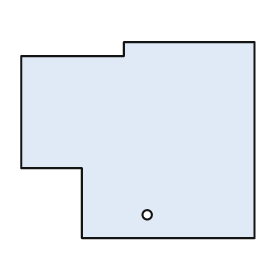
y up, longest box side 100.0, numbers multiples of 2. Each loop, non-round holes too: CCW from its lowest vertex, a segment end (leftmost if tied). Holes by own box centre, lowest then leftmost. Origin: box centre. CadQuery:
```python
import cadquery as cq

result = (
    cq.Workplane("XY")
    .moveTo(-24.0, -42.0)
    .lineTo(50.0, -42.0)
    .lineTo(50.0, 42.0)
    .lineTo(-6.0, 42.0)
    .lineTo(-6.0, 36.0)
    .lineTo(-50.0, 36.0)
    .lineTo(-50.0, -12.0)
    .lineTo(-24.0, -12.0)
    .close()
    .moveTo(4.0, -32.0)
    .circle(2.0)
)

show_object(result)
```